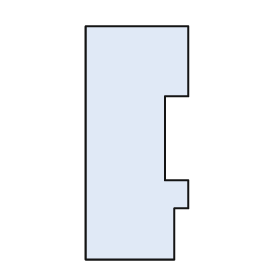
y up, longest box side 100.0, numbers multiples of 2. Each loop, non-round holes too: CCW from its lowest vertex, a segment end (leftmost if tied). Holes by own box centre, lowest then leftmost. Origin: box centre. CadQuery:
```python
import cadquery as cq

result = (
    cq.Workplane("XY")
    .moveTo(-22.0, -50.0)
    .lineTo(16.0, -50.0)
    .lineTo(16.0, -28.0)
    .lineTo(22.0, -28.0)
    .lineTo(22.0, -16.0)
    .lineTo(12.0, -16.0)
    .lineTo(12.0, 20.0)
    .lineTo(22.0, 20.0)
    .lineTo(22.0, 50.0)
    .lineTo(-22.0, 50.0)
    .close()
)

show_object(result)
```